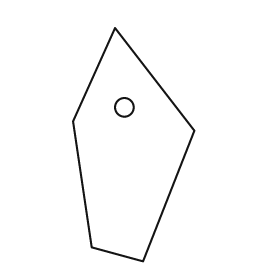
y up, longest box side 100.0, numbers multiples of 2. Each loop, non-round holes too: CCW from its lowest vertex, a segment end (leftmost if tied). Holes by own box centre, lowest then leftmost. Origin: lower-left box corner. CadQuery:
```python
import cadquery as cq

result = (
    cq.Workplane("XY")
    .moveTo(30.0, 0.0)
    .lineTo(52.0, 56.0)
    .lineTo(18.0, 100.0)
    .lineTo(0.0, 60.0)
    .lineTo(8.0, 6.0)
    .close()
    .moveTo(22.0, 66.0)
    .circle(4.0)
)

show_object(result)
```